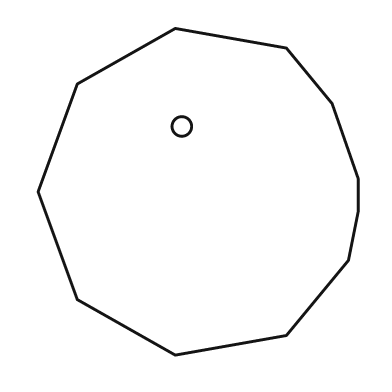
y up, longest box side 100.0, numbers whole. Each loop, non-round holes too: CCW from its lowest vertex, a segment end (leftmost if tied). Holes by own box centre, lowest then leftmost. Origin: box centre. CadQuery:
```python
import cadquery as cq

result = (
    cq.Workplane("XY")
    .moveTo(-7.0, -50.0)
    .lineTo(27.0, -44.0)
    .lineTo(46.0, -21.0)
    .lineTo(49.0, -6.0)
    .lineTo(49.0, 4.0)
    .lineTo(41.0, 27.0)
    .lineTo(27.0, 44.0)
    .lineTo(-7.0, 50.0)
    .lineTo(-37.0, 33.0)
    .lineTo(-49.0, 0.0)
    .lineTo(-37.0, -33.0)
    .close()
    .moveTo(-5.0, 20.0)
    .circle(3.0)
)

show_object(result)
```